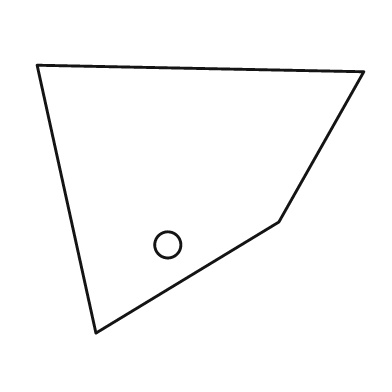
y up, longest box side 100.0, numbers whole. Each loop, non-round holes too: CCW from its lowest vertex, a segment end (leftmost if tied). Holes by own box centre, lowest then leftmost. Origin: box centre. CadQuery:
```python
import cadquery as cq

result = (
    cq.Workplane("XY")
    .moveTo(-32.0, -41.0)
    .lineTo(24.0, -7.0)
    .lineTo(50.0, 39.0)
    .lineTo(-50.0, 41.0)
    .close()
    .moveTo(-10.0, -14.0)
    .circle(4.0)
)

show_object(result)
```